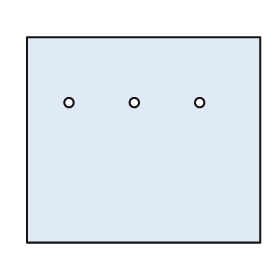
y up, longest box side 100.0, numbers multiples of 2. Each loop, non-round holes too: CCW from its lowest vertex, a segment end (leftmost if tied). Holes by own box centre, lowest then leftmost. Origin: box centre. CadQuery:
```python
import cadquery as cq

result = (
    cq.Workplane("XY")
    .moveTo(-50.0, -44.0)
    .lineTo(50.0, -44.0)
    .lineTo(50.0, 44.0)
    .lineTo(-50.0, 44.0)
    .close()
    .moveTo(-32.0, 16.0)
    .circle(2.0)
    .moveTo(-4.0, 16.0)
    .circle(2.0)
    .moveTo(24.0, 16.0)
    .circle(2.0)
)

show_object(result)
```